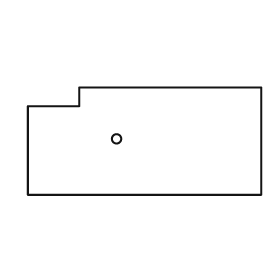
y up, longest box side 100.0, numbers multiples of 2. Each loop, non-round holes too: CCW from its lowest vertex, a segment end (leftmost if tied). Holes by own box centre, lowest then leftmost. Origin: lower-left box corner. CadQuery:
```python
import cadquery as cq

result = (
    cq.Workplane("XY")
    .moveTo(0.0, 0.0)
    .lineTo(100.0, 0.0)
    .lineTo(100.0, 46.0)
    .lineTo(22.0, 46.0)
    .lineTo(22.0, 38.0)
    .lineTo(0.0, 38.0)
    .close()
    .moveTo(38.0, 24.0)
    .circle(2.0)
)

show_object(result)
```